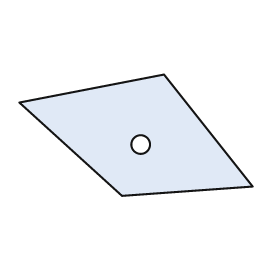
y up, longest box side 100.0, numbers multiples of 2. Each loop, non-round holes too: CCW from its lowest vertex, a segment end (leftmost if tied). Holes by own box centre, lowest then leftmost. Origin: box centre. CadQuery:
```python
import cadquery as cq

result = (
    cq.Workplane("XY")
    .moveTo(-6.0, -26.0)
    .lineTo(50.0, -22.0)
    .lineTo(12.0, 26.0)
    .lineTo(-50.0, 14.0)
    .close()
    .moveTo(2.0, -4.0)
    .circle(4.0)
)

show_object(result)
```